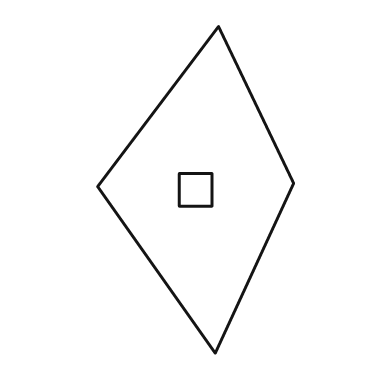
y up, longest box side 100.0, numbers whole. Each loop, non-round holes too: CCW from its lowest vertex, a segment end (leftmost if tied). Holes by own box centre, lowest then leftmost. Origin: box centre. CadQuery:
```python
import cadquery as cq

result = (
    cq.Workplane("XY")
    .moveTo(6.0, -50.0)
    .lineTo(30.0, 2.0)
    .lineTo(7.0, 50.0)
    .lineTo(-30.0, 1.0)
    .close()
    .moveTo(-5.0, -5.0)
    .lineTo(5.0, -5.0)
    .lineTo(5.0, 5.0)
    .lineTo(-5.0, 5.0)
    .close()
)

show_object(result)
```